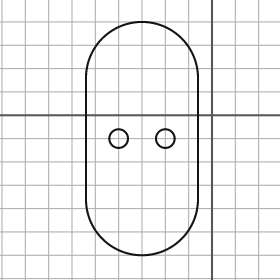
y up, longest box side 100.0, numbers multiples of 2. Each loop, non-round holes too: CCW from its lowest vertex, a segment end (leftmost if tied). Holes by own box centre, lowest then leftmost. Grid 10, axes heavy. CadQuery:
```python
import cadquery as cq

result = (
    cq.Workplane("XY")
    .moveTo(-54.0, -36.0)
    .threePointArc((-30.0, -60.0), (-6.0, -36.0))
    .lineTo(-6.0, 16.0)
    .threePointArc((-30.0, 40.0), (-54.0, 16.0))
    .close()
    .moveTo(-40.0, -10.0)
    .circle(4.0)
    .moveTo(-20.0, -10.0)
    .circle(4.0)
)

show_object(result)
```